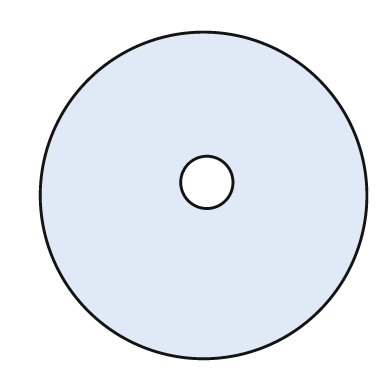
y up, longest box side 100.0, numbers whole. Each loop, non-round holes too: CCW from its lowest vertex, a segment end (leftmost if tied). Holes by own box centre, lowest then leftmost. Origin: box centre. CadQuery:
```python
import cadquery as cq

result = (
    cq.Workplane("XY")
    .moveTo(0.0, 0.0)
    .circle(50.0)
    .moveTo(1.0, 4.0)
    .circle(8.0)
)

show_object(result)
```